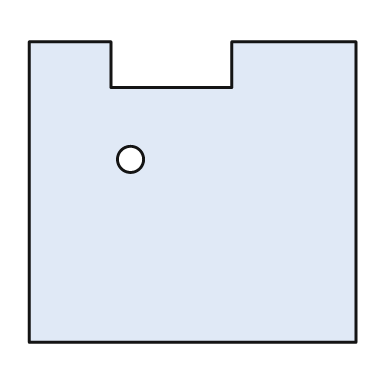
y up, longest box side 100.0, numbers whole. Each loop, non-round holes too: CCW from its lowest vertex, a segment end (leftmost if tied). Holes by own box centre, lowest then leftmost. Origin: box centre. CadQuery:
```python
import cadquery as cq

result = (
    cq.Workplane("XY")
    .moveTo(-50.0, -46.0)
    .lineTo(50.0, -46.0)
    .lineTo(50.0, 46.0)
    .lineTo(12.0, 46.0)
    .lineTo(12.0, 32.0)
    .lineTo(-25.0, 32.0)
    .lineTo(-25.0, 46.0)
    .lineTo(-50.0, 46.0)
    .close()
    .moveTo(-19.0, 10.0)
    .circle(4.0)
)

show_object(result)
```